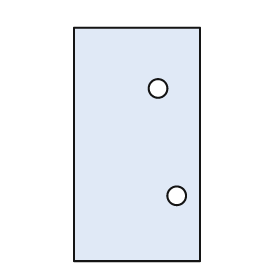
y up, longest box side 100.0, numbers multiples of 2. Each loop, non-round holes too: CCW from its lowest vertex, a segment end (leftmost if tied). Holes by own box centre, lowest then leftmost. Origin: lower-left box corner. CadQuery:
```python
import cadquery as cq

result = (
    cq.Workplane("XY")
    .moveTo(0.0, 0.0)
    .lineTo(54.0, 0.0)
    .lineTo(54.0, 100.0)
    .lineTo(0.0, 100.0)
    .close()
    .moveTo(44.0, 28.0)
    .circle(4.0)
    .moveTo(36.0, 74.0)
    .circle(4.0)
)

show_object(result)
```